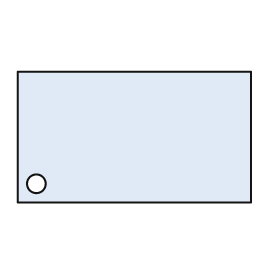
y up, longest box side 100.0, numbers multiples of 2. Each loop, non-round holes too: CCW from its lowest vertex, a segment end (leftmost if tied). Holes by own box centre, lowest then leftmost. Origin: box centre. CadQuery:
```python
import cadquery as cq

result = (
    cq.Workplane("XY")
    .moveTo(-50.0, -28.0)
    .lineTo(50.0, -28.0)
    .lineTo(50.0, 28.0)
    .lineTo(-50.0, 28.0)
    .close()
    .moveTo(-42.0, -20.0)
    .circle(4.0)
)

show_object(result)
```